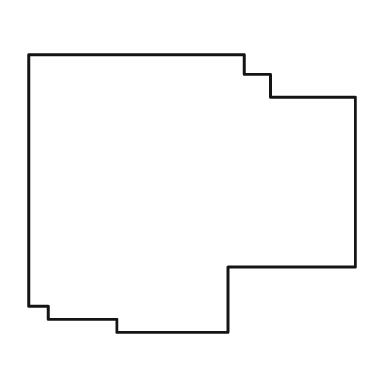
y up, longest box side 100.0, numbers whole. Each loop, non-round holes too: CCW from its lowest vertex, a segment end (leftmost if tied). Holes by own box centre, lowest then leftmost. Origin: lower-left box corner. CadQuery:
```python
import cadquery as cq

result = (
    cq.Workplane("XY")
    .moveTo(27.0, 0.0)
    .lineTo(61.0, 0.0)
    .lineTo(61.0, 20.0)
    .lineTo(100.0, 20.0)
    .lineTo(100.0, 72.0)
    .lineTo(74.0, 72.0)
    .lineTo(74.0, 79.0)
    .lineTo(66.0, 79.0)
    .lineTo(66.0, 85.0)
    .lineTo(0.0, 85.0)
    .lineTo(0.0, 8.0)
    .lineTo(6.0, 8.0)
    .lineTo(6.0, 4.0)
    .lineTo(27.0, 4.0)
    .close()
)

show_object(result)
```